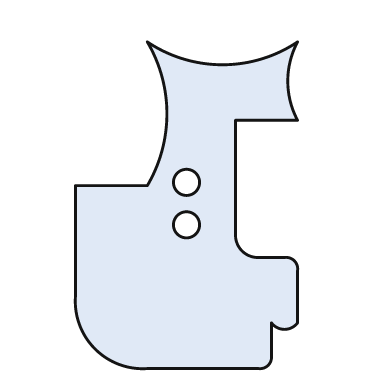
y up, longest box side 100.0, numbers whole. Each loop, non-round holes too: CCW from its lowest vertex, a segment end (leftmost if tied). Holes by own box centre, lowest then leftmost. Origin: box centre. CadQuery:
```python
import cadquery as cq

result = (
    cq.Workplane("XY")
    .moveTo(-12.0, -50.0)
    .lineTo(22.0, -50.0)
    .threePointArc((25.0, -49.0), (26.0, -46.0))
    .lineTo(26.0, -36.0)
    .threePointArc((30.0, -38.0), (34.0, -36.0))
    .lineTo(34.0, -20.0)
    .threePointArc((33.0, -17.0), (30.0, -16.0))
    .lineTo(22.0, -16.0)
    .threePointArc((17.0, -14.0), (15.0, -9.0))
    .lineTo(15.0, 26.0)
    .lineTo(34.0, 26.0)
    .threePointArc((31.0, 38.0), (34.0, 50.0))
    .threePointArc((11.0, 43.0), (-12.0, 50.0))
    .threePointArc((-6.0, 28.0), (-12.0, 6.0))
    .lineTo(-34.0, 6.0)
    .lineTo(-34.0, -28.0)
    .threePointArc((-28.0, -44.0), (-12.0, -50.0))
    .close()
    .moveTo(0.0, -6.0)
    .circle(4.0)
    .moveTo(0.0, 7.0)
    .circle(4.0)
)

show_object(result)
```